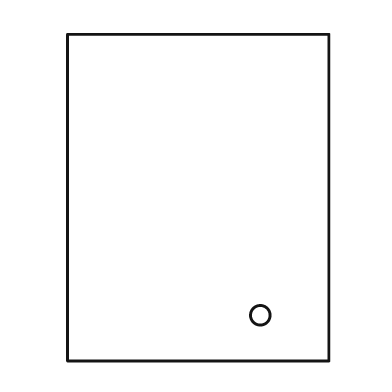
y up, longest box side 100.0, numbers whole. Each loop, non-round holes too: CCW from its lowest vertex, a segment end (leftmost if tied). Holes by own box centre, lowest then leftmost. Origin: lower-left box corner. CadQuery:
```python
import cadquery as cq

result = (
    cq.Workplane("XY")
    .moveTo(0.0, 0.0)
    .lineTo(80.0, 0.0)
    .lineTo(80.0, 100.0)
    .lineTo(0.0, 100.0)
    .close()
    .moveTo(59.0, 14.0)
    .circle(3.0)
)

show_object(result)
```